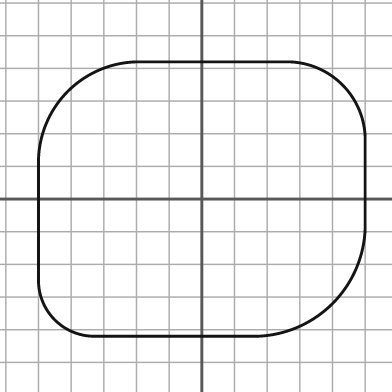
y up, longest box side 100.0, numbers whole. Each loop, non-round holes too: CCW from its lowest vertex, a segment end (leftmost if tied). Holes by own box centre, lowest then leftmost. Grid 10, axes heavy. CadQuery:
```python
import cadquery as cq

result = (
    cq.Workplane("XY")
    .moveTo(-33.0, -42.0)
    .lineTo(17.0, -42.0)
    .threePointArc((40.0, -32.0), (50.0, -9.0))
    .lineTo(50.0, 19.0)
    .threePointArc((43.0, 35.0), (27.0, 42.0))
    .lineTo(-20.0, 42.0)
    .threePointArc((-41.0, 33.0), (-50.0, 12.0))
    .lineTo(-50.0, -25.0)
    .threePointArc((-45.0, -37.0), (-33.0, -42.0))
    .close()
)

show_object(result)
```